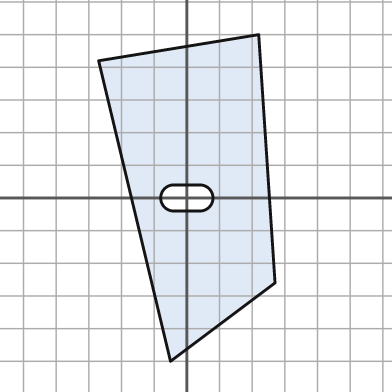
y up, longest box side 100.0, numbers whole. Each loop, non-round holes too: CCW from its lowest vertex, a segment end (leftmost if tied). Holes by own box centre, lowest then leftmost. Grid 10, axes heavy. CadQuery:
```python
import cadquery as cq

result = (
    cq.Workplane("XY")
    .moveTo(-5.0, -50.0)
    .lineTo(27.0, -26.0)
    .lineTo(22.0, 50.0)
    .lineTo(-27.0, 42.0)
    .close()
    .moveTo(-4.0, -4.0)
    .lineTo(4.0, -4.0)
    .threePointArc((8.0, 0.0), (4.0, 4.0))
    .lineTo(-4.0, 4.0)
    .threePointArc((-8.0, 0.0), (-4.0, -4.0))
    .close()
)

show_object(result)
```